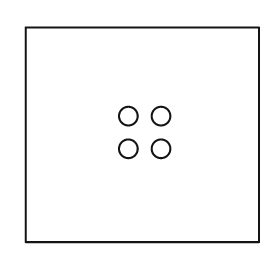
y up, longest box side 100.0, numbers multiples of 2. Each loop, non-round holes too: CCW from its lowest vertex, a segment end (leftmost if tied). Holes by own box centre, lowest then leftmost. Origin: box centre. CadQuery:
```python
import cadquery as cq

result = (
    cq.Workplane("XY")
    .moveTo(-50.0, -46.0)
    .lineTo(50.0, -46.0)
    .lineTo(50.0, 46.0)
    .lineTo(-50.0, 46.0)
    .close()
    .moveTo(-6.0, -6.0)
    .circle(4.0)
    .moveTo(8.0, -6.0)
    .circle(4.0)
    .moveTo(-6.0, 8.0)
    .circle(4.0)
    .moveTo(8.0, 8.0)
    .circle(4.0)
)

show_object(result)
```